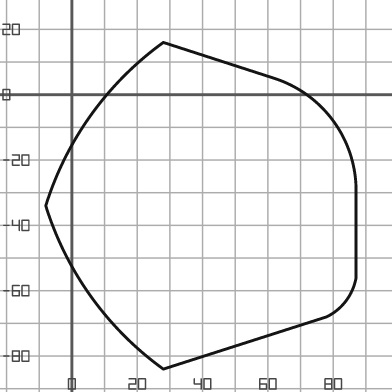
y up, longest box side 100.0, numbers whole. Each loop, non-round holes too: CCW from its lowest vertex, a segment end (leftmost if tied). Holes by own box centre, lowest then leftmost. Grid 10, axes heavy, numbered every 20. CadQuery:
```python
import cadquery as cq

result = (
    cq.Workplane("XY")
    .moveTo(28.0, -84.0)
    .lineTo(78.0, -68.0)
    .threePointArc((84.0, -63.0), (87.0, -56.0))
    .lineTo(87.0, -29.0)
    .threePointArc((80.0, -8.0), (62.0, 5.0))
    .lineTo(28.0, 16.0)
    .threePointArc((6.0, -6.0), (-8.0, -34.0))
    .threePointArc((6.0, -62.0), (28.0, -84.0))
    .close()
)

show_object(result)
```